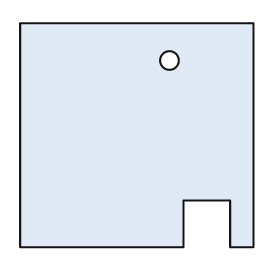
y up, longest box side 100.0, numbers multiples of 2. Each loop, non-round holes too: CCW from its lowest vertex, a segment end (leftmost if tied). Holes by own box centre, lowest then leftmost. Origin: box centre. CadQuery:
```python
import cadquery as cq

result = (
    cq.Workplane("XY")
    .moveTo(-50.0, -48.0)
    .lineTo(20.0, -48.0)
    .lineTo(20.0, -28.0)
    .lineTo(40.0, -28.0)
    .lineTo(40.0, -48.0)
    .lineTo(50.0, -48.0)
    .lineTo(50.0, 48.0)
    .lineTo(-50.0, 48.0)
    .close()
    .moveTo(14.0, 32.0)
    .circle(4.0)
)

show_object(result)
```